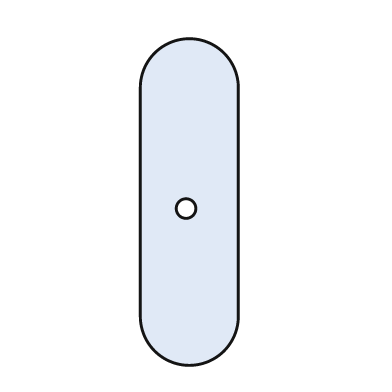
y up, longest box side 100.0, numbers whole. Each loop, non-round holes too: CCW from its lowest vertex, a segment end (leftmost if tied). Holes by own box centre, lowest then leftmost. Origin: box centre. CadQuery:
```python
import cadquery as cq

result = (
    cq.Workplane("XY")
    .moveTo(-15.0, -35.0)
    .threePointArc((0.0, -50.0), (15.0, -35.0))
    .lineTo(15.0, 35.0)
    .threePointArc((0.0, 50.0), (-15.0, 35.0))
    .close()
    .moveTo(-1.0, -2.0)
    .circle(3.0)
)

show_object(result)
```